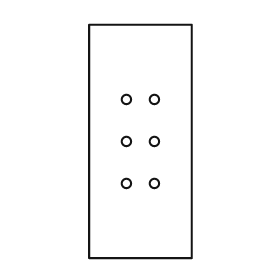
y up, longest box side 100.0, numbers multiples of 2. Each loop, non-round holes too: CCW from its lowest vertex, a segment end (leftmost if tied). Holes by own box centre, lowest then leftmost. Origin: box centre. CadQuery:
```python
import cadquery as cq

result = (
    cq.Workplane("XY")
    .moveTo(-22.0, -50.0)
    .lineTo(22.0, -50.0)
    .lineTo(22.0, 50.0)
    .lineTo(-22.0, 50.0)
    .close()
    .moveTo(-6.0, -18.0)
    .circle(2.0)
    .moveTo(6.0, -18.0)
    .circle(2.0)
    .moveTo(-6.0, 0.0)
    .circle(2.0)
    .moveTo(6.0, 0.0)
    .circle(2.0)
    .moveTo(-6.0, 18.0)
    .circle(2.0)
    .moveTo(6.0, 18.0)
    .circle(2.0)
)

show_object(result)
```